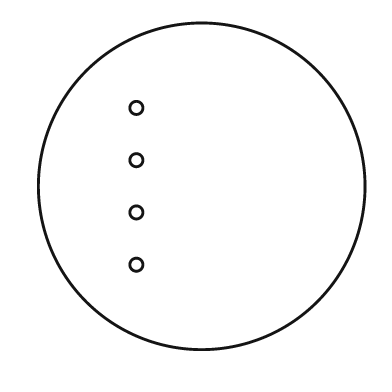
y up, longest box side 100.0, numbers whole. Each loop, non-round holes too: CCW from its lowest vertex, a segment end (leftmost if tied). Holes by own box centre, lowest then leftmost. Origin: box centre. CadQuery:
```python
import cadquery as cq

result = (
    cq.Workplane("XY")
    .moveTo(0.0, 0.0)
    .circle(50.0)
    .moveTo(-20.0, -24.0)
    .circle(2.0)
    .moveTo(-20.0, -8.0)
    .circle(2.0)
    .moveTo(-20.0, 8.0)
    .circle(2.0)
    .moveTo(-20.0, 24.0)
    .circle(2.0)
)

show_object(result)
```